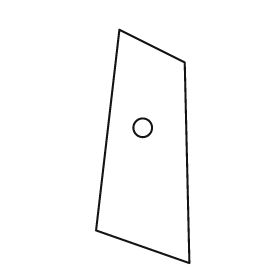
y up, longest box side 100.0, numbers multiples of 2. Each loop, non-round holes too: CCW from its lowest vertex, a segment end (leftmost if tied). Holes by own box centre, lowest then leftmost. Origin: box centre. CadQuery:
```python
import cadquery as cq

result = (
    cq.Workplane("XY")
    .moveTo(20.0, -50.0)
    .lineTo(18.0, 36.0)
    .lineTo(-10.0, 50.0)
    .lineTo(-20.0, -36.0)
    .close()
    .moveTo(0.0, 8.0)
    .circle(4.0)
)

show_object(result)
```